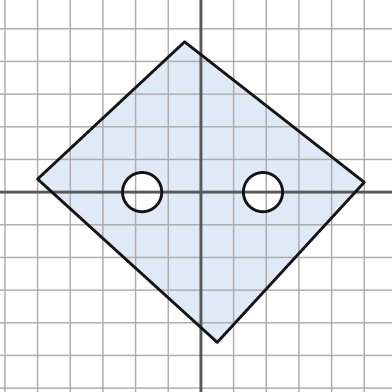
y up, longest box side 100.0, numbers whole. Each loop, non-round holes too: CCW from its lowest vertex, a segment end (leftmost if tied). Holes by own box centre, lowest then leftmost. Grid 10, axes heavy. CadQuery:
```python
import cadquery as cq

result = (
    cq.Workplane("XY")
    .moveTo(5.0, -46.0)
    .lineTo(50.0, 3.0)
    .lineTo(-5.0, 46.0)
    .lineTo(-50.0, 4.0)
    .close()
    .moveTo(-18.0, 0.0)
    .circle(6.0)
    .moveTo(19.0, 0.0)
    .circle(6.0)
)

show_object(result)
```